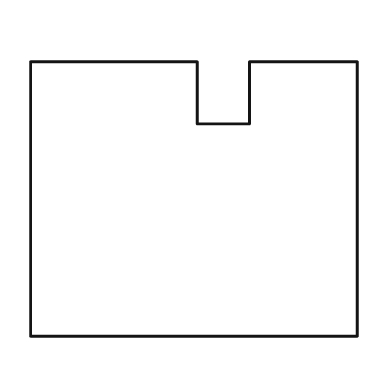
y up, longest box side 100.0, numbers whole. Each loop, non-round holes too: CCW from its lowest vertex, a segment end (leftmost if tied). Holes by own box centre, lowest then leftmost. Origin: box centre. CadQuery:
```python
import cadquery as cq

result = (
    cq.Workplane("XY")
    .moveTo(-50.0, -42.0)
    .lineTo(50.0, -42.0)
    .lineTo(50.0, 42.0)
    .lineTo(17.0, 42.0)
    .lineTo(17.0, 23.0)
    .lineTo(1.0, 23.0)
    .lineTo(1.0, 42.0)
    .lineTo(-50.0, 42.0)
    .close()
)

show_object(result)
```